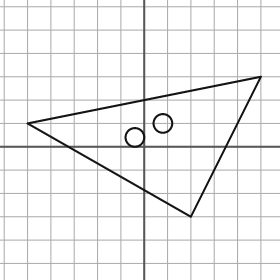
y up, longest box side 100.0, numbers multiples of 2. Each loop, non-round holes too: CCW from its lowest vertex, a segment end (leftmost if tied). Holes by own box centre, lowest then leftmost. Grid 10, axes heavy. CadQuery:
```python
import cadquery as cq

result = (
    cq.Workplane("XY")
    .moveTo(20.0, -30.0)
    .lineTo(50.0, 30.0)
    .lineTo(-50.0, 10.0)
    .close()
    .moveTo(-4.0, 4.0)
    .circle(4.0)
    .moveTo(8.0, 10.0)
    .circle(4.0)
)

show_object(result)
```